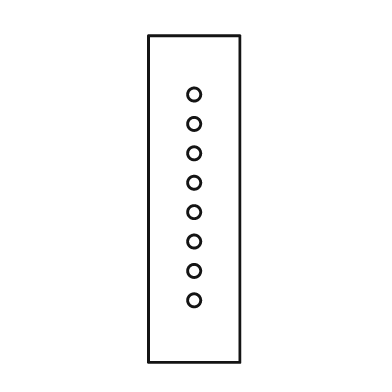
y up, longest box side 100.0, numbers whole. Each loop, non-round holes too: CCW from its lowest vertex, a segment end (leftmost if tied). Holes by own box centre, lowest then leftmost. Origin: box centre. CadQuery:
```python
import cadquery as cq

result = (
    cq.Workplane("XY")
    .moveTo(-14.0, -50.0)
    .lineTo(14.0, -50.0)
    .lineTo(14.0, 50.0)
    .lineTo(-14.0, 50.0)
    .close()
    .moveTo(0.0, -31.0)
    .circle(2.0)
    .moveTo(0.0, -22.0)
    .circle(2.0)
    .moveTo(0.0, -13.0)
    .circle(2.0)
    .moveTo(0.0, -4.0)
    .circle(2.0)
    .moveTo(0.0, 5.0)
    .circle(2.0)
    .moveTo(0.0, 14.0)
    .circle(2.0)
    .moveTo(0.0, 23.0)
    .circle(2.0)
    .moveTo(0.0, 32.0)
    .circle(2.0)
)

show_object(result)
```